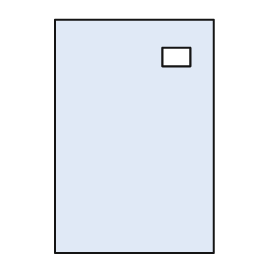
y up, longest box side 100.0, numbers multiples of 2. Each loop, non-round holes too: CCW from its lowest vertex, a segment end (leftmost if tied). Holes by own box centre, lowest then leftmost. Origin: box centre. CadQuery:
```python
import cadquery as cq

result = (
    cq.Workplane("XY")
    .moveTo(-34.0, -50.0)
    .lineTo(34.0, -50.0)
    .lineTo(34.0, 50.0)
    .lineTo(-34.0, 50.0)
    .close()
    .moveTo(12.0, 30.0)
    .lineTo(24.0, 30.0)
    .lineTo(24.0, 38.0)
    .lineTo(12.0, 38.0)
    .close()
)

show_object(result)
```